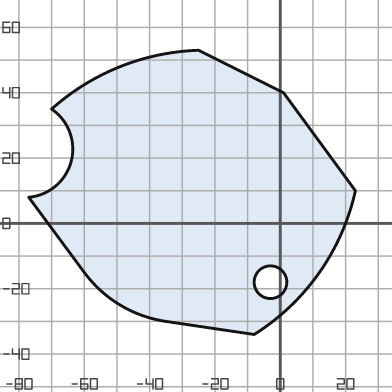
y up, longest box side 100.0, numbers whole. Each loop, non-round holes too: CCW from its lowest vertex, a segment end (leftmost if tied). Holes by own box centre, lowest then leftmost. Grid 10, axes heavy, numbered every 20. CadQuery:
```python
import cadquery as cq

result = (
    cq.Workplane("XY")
    .moveTo(-8.0, -34.0)
    .threePointArc((12.0, -15.0), (23.0, 10.0))
    .lineTo(1.0, 40.0)
    .lineTo(-25.0, 53.0)
    .threePointArc((-49.0, 48.0), (-70.0, 35.0))
    .threePointArc((-64.0, 19.0), (-77.0, 8.0))
    .lineTo(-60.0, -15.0)
    .threePointArc((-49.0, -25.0), (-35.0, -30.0))
    .close()
    .moveTo(-3.0, -18.0)
    .circle(5.0)
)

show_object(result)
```